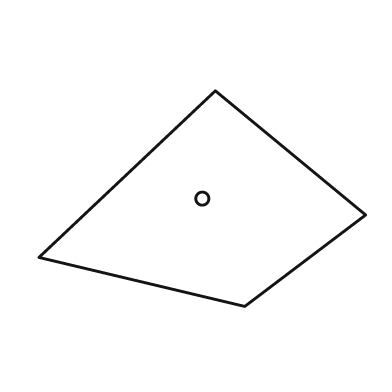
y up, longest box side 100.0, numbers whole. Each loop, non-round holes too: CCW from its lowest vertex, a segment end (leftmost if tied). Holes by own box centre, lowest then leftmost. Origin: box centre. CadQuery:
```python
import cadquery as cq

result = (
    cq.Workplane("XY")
    .moveTo(13.0, -33.0)
    .lineTo(50.0, -5.0)
    .lineTo(4.0, 33.0)
    .lineTo(-50.0, -18.0)
    .close()
    .moveTo(0.0, 0.0)
    .circle(2.0)
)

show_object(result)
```